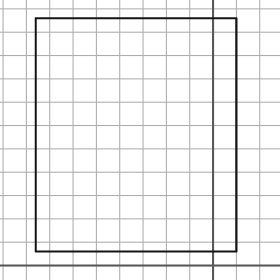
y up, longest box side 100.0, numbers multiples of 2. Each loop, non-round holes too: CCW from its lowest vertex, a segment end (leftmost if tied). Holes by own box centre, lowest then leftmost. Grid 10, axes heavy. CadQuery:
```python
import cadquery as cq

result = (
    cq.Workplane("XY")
    .moveTo(-76.0, 6.0)
    .lineTo(10.0, 6.0)
    .lineTo(10.0, 106.0)
    .lineTo(-76.0, 106.0)
    .close()
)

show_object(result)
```